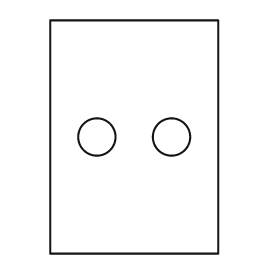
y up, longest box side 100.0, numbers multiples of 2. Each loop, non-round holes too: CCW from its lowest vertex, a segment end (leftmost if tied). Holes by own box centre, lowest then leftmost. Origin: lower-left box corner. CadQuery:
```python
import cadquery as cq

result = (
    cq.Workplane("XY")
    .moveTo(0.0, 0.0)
    .lineTo(72.0, 0.0)
    .lineTo(72.0, 100.0)
    .lineTo(0.0, 100.0)
    .close()
    .moveTo(20.0, 50.0)
    .circle(8.0)
    .moveTo(52.0, 50.0)
    .circle(8.0)
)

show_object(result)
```